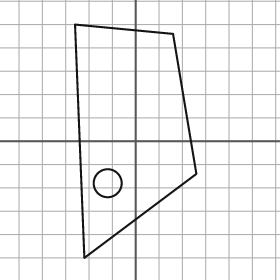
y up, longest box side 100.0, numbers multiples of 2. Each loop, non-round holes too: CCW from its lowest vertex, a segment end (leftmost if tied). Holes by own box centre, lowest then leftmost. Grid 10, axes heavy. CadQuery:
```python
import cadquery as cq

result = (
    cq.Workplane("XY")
    .moveTo(-22.0, -50.0)
    .lineTo(26.0, -14.0)
    .lineTo(16.0, 46.0)
    .lineTo(-26.0, 50.0)
    .close()
    .moveTo(-12.0, -18.0)
    .circle(6.0)
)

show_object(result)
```